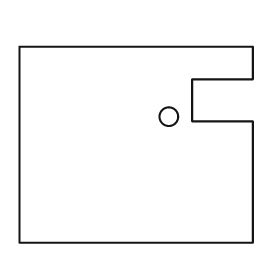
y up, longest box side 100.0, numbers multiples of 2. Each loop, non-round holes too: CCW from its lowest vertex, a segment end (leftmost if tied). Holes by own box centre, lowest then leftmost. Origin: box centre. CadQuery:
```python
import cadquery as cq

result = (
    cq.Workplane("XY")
    .moveTo(-50.0, -42.0)
    .lineTo(50.0, -42.0)
    .lineTo(50.0, 10.0)
    .lineTo(24.0, 10.0)
    .lineTo(24.0, 28.0)
    .lineTo(50.0, 28.0)
    .lineTo(50.0, 42.0)
    .lineTo(-50.0, 42.0)
    .close()
    .moveTo(14.0, 12.0)
    .circle(4.0)
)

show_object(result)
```